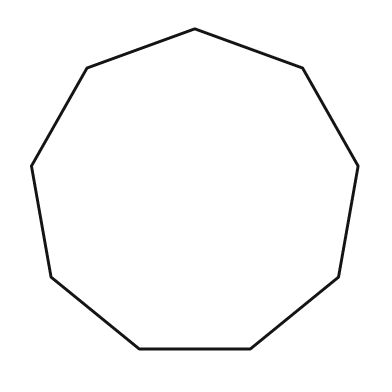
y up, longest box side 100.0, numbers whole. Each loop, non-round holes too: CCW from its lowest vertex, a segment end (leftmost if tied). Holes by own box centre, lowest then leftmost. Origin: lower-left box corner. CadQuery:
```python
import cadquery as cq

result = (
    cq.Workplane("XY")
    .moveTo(33.0, 0.0)
    .lineTo(67.0, 0.0)
    .lineTo(94.0, 22.0)
    .lineTo(100.0, 56.0)
    .lineTo(83.0, 86.0)
    .lineTo(50.0, 98.0)
    .lineTo(17.0, 86.0)
    .lineTo(0.0, 56.0)
    .lineTo(6.0, 22.0)
    .close()
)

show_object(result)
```